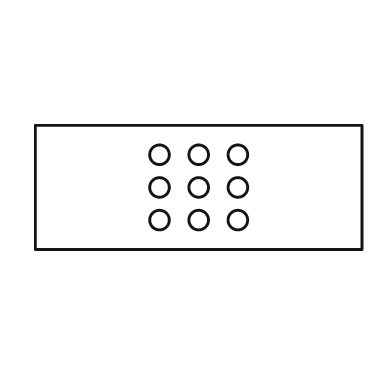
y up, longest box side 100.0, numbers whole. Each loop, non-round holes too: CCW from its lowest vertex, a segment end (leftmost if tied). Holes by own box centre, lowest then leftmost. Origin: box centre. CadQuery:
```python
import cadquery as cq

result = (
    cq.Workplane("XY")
    .moveTo(-50.0, -19.0)
    .lineTo(50.0, -19.0)
    .lineTo(50.0, 19.0)
    .lineTo(-50.0, 19.0)
    .close()
    .moveTo(-12.0, -10.0)
    .circle(3.0)
    .moveTo(0.0, -10.0)
    .circle(3.0)
    .moveTo(12.0, -10.0)
    .circle(3.0)
    .moveTo(-12.0, 0.0)
    .circle(3.0)
    .moveTo(0.0, 0.0)
    .circle(3.0)
    .moveTo(12.0, 0.0)
    .circle(3.0)
    .moveTo(-12.0, 10.0)
    .circle(3.0)
    .moveTo(0.0, 10.0)
    .circle(3.0)
    .moveTo(12.0, 10.0)
    .circle(3.0)
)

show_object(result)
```